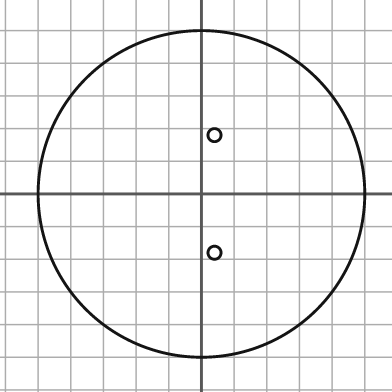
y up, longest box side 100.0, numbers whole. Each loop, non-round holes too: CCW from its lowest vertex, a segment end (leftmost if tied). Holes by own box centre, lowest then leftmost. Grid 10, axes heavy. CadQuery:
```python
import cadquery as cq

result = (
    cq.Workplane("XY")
    .moveTo(0.0, 0.0)
    .circle(50.0)
    .moveTo(4.0, -18.0)
    .circle(2.0)
    .moveTo(4.0, 18.0)
    .circle(2.0)
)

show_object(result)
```